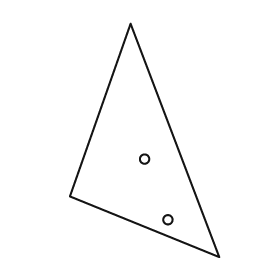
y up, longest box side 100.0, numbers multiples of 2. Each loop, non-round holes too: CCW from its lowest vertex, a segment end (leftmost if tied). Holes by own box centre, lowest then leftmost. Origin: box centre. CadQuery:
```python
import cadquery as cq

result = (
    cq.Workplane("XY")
    .moveTo(32.0, -50.0)
    .lineTo(-6.0, 50.0)
    .lineTo(-32.0, -24.0)
    .close()
    .moveTo(10.0, -34.0)
    .circle(2.0)
    .moveTo(0.0, -8.0)
    .circle(2.0)
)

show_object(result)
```